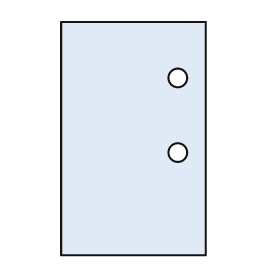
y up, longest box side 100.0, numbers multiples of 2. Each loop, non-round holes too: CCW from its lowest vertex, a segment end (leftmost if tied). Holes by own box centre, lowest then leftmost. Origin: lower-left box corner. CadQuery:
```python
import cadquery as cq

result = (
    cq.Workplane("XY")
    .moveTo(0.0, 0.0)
    .lineTo(62.0, 0.0)
    .lineTo(62.0, 100.0)
    .lineTo(0.0, 100.0)
    .close()
    .moveTo(50.0, 44.0)
    .circle(4.0)
    .moveTo(50.0, 76.0)
    .circle(4.0)
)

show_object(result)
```